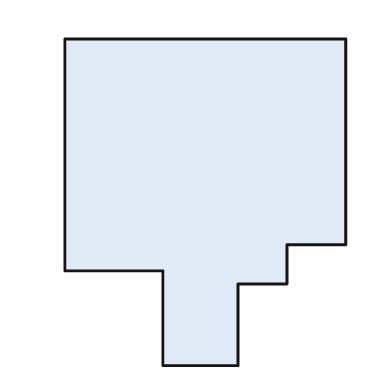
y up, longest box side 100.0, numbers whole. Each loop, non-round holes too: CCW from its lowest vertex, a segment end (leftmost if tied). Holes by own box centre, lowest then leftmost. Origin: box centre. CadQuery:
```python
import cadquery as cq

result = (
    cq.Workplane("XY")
    .moveTo(-13.0, -50.0)
    .lineTo(10.0, -50.0)
    .lineTo(10.0, -25.0)
    .lineTo(25.0, -25.0)
    .lineTo(25.0, -13.0)
    .lineTo(43.0, -13.0)
    .lineTo(43.0, 50.0)
    .lineTo(-43.0, 50.0)
    .lineTo(-43.0, -21.0)
    .lineTo(-13.0, -21.0)
    .close()
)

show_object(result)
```